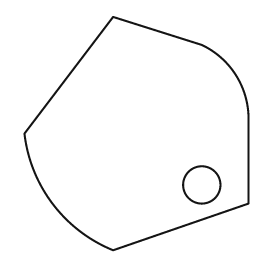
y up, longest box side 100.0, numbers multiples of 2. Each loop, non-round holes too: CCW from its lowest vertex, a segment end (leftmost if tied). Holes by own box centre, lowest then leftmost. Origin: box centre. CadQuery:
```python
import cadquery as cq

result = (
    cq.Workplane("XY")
    .moveTo(-10.0, -50.0)
    .lineTo(48.0, -30.0)
    .lineTo(48.0, 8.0)
    .threePointArc((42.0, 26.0), (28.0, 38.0))
    .lineTo(-10.0, 50.0)
    .lineTo(-48.0, 0.0)
    .threePointArc((-36.0, -30.0), (-10.0, -50.0))
    .close()
    .moveTo(28.0, -22.0)
    .circle(8.0)
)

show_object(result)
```